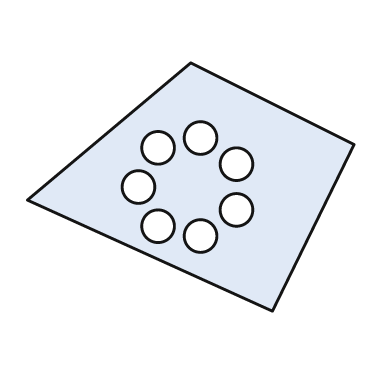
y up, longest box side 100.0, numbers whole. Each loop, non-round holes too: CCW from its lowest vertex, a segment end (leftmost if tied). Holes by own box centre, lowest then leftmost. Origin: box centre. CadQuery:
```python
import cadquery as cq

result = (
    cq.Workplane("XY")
    .moveTo(25.0, -38.0)
    .lineTo(50.0, 13.0)
    .lineTo(0.0, 38.0)
    .lineTo(-50.0, -4.0)
    .close()
    .moveTo(3.0, -15.0)
    .circle(5.0)
    .moveTo(-10.0, -12.0)
    .circle(5.0)
    .moveTo(14.0, -7.0)
    .circle(5.0)
    .moveTo(-16.0, 0.0)
    .circle(5.0)
    .moveTo(14.0, 7.0)
    .circle(5.0)
    .moveTo(-10.0, 12.0)
    .circle(5.0)
    .moveTo(3.0, 15.0)
    .circle(5.0)
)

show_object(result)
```